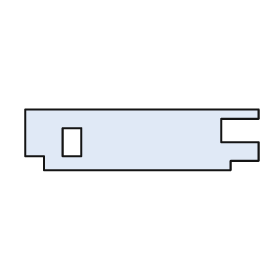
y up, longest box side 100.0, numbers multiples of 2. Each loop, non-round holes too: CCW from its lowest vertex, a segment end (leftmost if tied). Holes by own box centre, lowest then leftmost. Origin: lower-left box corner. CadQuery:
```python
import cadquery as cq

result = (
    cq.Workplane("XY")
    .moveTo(8.0, 0.0)
    .lineTo(88.0, 0.0)
    .lineTo(88.0, 4.0)
    .lineTo(100.0, 4.0)
    .lineTo(100.0, 12.0)
    .lineTo(84.0, 12.0)
    .lineTo(84.0, 22.0)
    .lineTo(100.0, 22.0)
    .lineTo(100.0, 26.0)
    .lineTo(0.0, 26.0)
    .lineTo(0.0, 6.0)
    .lineTo(8.0, 6.0)
    .close()
    .moveTo(16.0, 6.0)
    .lineTo(24.0, 6.0)
    .lineTo(24.0, 18.0)
    .lineTo(16.0, 18.0)
    .close()
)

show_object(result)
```